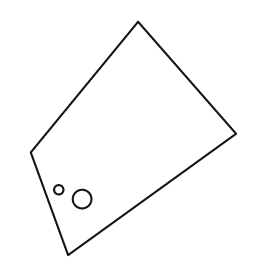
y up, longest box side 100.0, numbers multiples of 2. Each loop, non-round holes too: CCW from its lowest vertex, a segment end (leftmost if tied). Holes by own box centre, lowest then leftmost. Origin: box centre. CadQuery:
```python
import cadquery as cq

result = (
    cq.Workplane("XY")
    .moveTo(-28.0, -50.0)
    .lineTo(44.0, 2.0)
    .lineTo(2.0, 50.0)
    .lineTo(-44.0, -6.0)
    .close()
    .moveTo(-22.0, -26.0)
    .circle(4.0)
    .moveTo(-32.0, -22.0)
    .circle(2.0)
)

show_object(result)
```